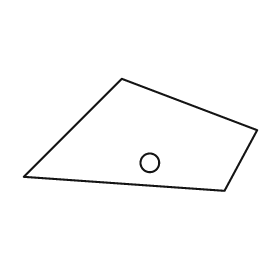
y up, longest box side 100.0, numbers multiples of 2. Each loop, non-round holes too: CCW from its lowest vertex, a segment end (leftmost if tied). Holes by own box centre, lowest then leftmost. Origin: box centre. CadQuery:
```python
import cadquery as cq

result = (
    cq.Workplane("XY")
    .moveTo(36.0, -24.0)
    .lineTo(50.0, 2.0)
    .lineTo(-8.0, 24.0)
    .lineTo(-50.0, -18.0)
    .close()
    .moveTo(4.0, -12.0)
    .circle(4.0)
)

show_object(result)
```